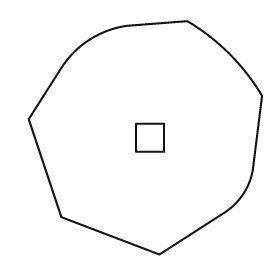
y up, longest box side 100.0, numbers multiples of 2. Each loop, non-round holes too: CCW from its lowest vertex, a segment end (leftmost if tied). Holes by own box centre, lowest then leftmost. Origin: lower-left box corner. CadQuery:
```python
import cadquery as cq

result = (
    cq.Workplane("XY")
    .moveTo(56.0, 0.0)
    .lineTo(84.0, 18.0)
    .threePointArc((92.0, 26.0), (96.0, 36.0))
    .lineTo(100.0, 68.0)
    .threePointArc((86.0, 86.0), (68.0, 100.0))
    .lineTo(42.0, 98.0)
    .threePointArc((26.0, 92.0), (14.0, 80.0))
    .lineTo(0.0, 58.0)
    .lineTo(14.0, 16.0)
    .close()
    .moveTo(46.0, 44.0)
    .lineTo(58.0, 44.0)
    .lineTo(58.0, 56.0)
    .lineTo(46.0, 56.0)
    .close()
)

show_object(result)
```